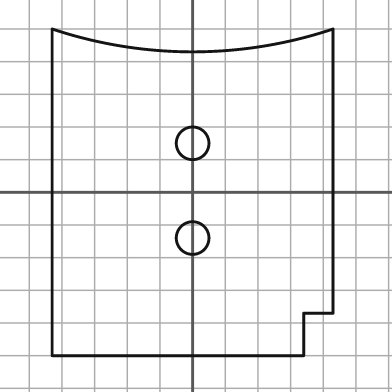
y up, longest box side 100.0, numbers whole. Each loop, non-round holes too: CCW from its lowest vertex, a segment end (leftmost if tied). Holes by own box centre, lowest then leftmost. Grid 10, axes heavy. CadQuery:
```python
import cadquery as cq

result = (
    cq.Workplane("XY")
    .moveTo(-43.0, -50.0)
    .lineTo(34.0, -50.0)
    .lineTo(34.0, -37.0)
    .lineTo(43.0, -37.0)
    .lineTo(43.0, 50.0)
    .threePointArc((0.0, 43.0), (-43.0, 50.0))
    .close()
    .moveTo(0.0, -14.0)
    .circle(5.0)
    .moveTo(0.0, 15.0)
    .circle(5.0)
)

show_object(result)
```